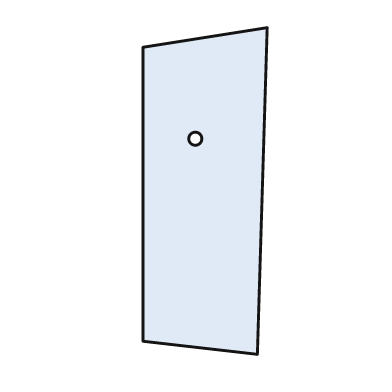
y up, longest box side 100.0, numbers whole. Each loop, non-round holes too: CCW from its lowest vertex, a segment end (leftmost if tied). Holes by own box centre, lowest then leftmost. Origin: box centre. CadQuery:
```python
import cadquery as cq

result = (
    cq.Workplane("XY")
    .moveTo(16.0, -50.0)
    .lineTo(19.0, 50.0)
    .lineTo(-19.0, 44.0)
    .lineTo(-19.0, -46.0)
    .close()
    .moveTo(-3.0, 16.0)
    .circle(2.0)
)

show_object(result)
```